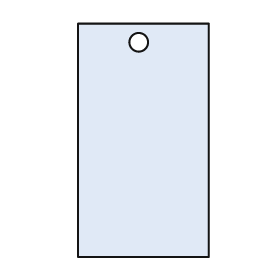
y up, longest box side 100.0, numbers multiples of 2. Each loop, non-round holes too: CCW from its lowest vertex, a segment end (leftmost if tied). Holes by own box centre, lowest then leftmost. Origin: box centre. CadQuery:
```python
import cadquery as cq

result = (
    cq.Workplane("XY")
    .moveTo(-28.0, -50.0)
    .lineTo(28.0, -50.0)
    .lineTo(28.0, 50.0)
    .lineTo(-28.0, 50.0)
    .close()
    .moveTo(-2.0, 42.0)
    .circle(4.0)
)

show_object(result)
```